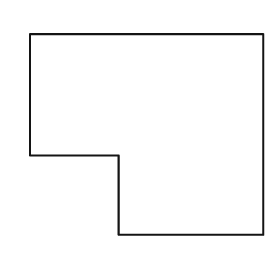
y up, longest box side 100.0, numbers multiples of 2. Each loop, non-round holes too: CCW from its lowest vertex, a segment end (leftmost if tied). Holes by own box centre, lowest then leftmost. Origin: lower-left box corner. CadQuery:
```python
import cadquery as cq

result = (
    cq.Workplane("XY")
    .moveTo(38.0, 0.0)
    .lineTo(100.0, 0.0)
    .lineTo(100.0, 86.0)
    .lineTo(0.0, 86.0)
    .lineTo(0.0, 34.0)
    .lineTo(38.0, 34.0)
    .close()
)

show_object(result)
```